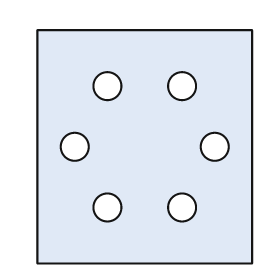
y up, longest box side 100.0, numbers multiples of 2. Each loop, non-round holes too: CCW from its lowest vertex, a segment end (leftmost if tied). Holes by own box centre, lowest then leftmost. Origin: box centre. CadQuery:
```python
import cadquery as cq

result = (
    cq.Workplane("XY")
    .moveTo(-46.0, -50.0)
    .lineTo(46.0, -50.0)
    .lineTo(46.0, 50.0)
    .lineTo(-46.0, 50.0)
    .close()
    .moveTo(-16.0, -26.0)
    .circle(6.0)
    .moveTo(16.0, -26.0)
    .circle(6.0)
    .moveTo(-30.0, 0.0)
    .circle(6.0)
    .moveTo(30.0, 0.0)
    .circle(6.0)
    .moveTo(-16.0, 26.0)
    .circle(6.0)
    .moveTo(16.0, 26.0)
    .circle(6.0)
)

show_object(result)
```